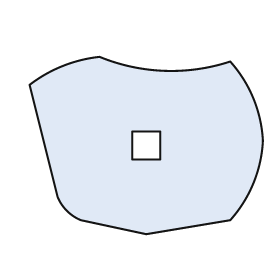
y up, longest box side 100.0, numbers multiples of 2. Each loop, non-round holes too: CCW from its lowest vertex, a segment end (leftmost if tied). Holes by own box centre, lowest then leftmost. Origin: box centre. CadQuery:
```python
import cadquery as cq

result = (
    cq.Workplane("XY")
    .moveTo(0.0, -38.0)
    .lineTo(36.0, -32.0)
    .threePointArc((46.0, -16.0), (50.0, 2.0))
    .threePointArc((46.0, 20.0), (36.0, 36.0))
    .threePointArc((8.0, 32.0), (-20.0, 38.0))
    .threePointArc((-36.0, 34.0), (-50.0, 26.0))
    .lineTo(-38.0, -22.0)
    .threePointArc((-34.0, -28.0), (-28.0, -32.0))
    .close()
    .moveTo(-6.0, -6.0)
    .lineTo(6.0, -6.0)
    .lineTo(6.0, 6.0)
    .lineTo(-6.0, 6.0)
    .close()
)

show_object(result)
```